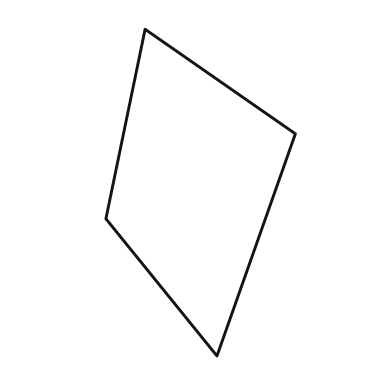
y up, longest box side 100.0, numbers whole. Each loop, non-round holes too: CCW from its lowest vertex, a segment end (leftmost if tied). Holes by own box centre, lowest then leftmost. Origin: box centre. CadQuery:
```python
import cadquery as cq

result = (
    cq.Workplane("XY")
    .moveTo(5.0, -50.0)
    .lineTo(29.0, 18.0)
    .lineTo(-17.0, 50.0)
    .lineTo(-29.0, -8.0)
    .close()
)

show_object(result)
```